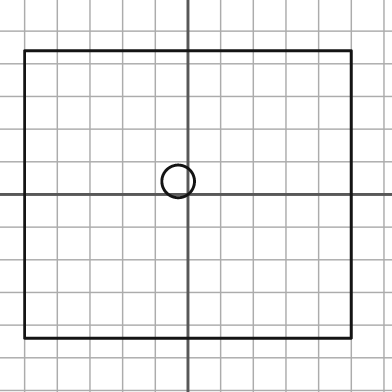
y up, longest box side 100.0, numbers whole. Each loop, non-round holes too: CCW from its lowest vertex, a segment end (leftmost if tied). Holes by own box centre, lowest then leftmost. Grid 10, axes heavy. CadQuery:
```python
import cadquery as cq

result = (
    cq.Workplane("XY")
    .moveTo(-50.0, -44.0)
    .lineTo(50.0, -44.0)
    .lineTo(50.0, 44.0)
    .lineTo(-50.0, 44.0)
    .close()
    .moveTo(-3.0, 4.0)
    .circle(5.0)
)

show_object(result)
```